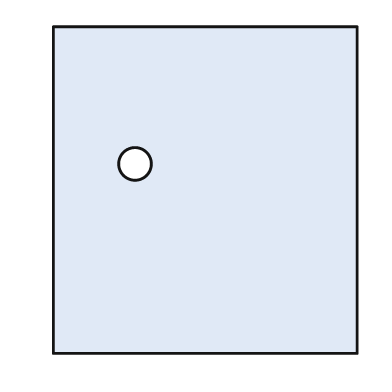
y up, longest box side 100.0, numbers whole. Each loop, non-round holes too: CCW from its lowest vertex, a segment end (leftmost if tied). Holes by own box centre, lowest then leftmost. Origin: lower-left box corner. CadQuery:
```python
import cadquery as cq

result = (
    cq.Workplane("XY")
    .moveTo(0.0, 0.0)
    .lineTo(93.0, 0.0)
    .lineTo(93.0, 100.0)
    .lineTo(0.0, 100.0)
    .close()
    .moveTo(25.0, 58.0)
    .circle(5.0)
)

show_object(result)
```